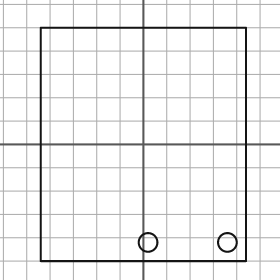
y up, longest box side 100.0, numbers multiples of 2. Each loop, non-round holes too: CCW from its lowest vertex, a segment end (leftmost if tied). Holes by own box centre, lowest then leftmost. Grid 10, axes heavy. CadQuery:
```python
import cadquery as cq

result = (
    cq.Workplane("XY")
    .moveTo(-44.0, -50.0)
    .lineTo(44.0, -50.0)
    .lineTo(44.0, 50.0)
    .lineTo(-44.0, 50.0)
    .close()
    .moveTo(2.0, -42.0)
    .circle(4.0)
    .moveTo(36.0, -42.0)
    .circle(4.0)
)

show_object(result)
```